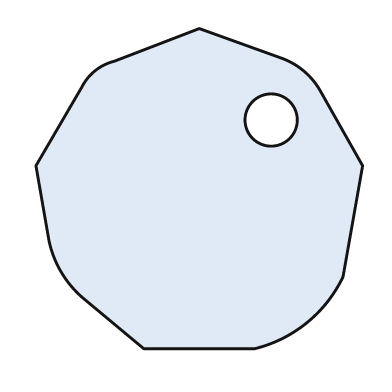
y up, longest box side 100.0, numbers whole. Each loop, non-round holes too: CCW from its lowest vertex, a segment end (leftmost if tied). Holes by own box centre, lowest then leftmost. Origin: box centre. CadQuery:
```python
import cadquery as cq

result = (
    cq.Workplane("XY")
    .moveTo(-17.0, -49.0)
    .lineTo(17.0, -49.0)
    .threePointArc((33.0, -41.0), (44.0, -27.0))
    .lineTo(50.0, 7.0)
    .lineTo(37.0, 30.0)
    .threePointArc((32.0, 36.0), (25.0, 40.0))
    .lineTo(0.0, 49.0)
    .lineTo(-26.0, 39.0)
    .threePointArc((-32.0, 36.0), (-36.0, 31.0))
    .lineTo(-50.0, 7.0)
    .lineTo(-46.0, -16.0)
    .threePointArc((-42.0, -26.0), (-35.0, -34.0))
    .close()
    .moveTo(22.0, 21.0)
    .circle(8.0)
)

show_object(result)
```